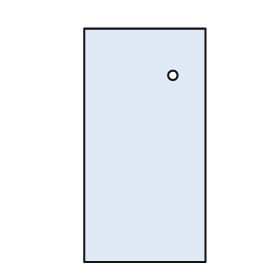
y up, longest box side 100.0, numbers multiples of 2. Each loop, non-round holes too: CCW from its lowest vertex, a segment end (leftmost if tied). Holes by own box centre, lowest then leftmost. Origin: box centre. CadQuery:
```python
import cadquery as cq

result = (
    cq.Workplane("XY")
    .moveTo(-26.0, -50.0)
    .lineTo(26.0, -50.0)
    .lineTo(26.0, 50.0)
    .lineTo(-26.0, 50.0)
    .close()
    .moveTo(12.0, 30.0)
    .circle(2.0)
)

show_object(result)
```